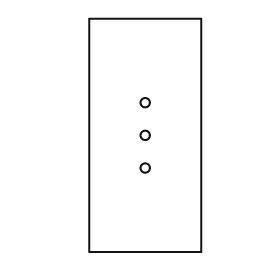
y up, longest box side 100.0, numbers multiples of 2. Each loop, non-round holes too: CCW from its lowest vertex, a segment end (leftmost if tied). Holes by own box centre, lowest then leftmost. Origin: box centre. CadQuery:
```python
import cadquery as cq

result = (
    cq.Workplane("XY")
    .moveTo(-24.0, -50.0)
    .lineTo(24.0, -50.0)
    .lineTo(24.0, 50.0)
    .lineTo(-24.0, 50.0)
    .close()
    .moveTo(0.0, -14.0)
    .circle(2.0)
    .moveTo(0.0, 0.0)
    .circle(2.0)
    .moveTo(0.0, 14.0)
    .circle(2.0)
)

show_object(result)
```